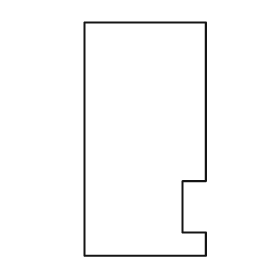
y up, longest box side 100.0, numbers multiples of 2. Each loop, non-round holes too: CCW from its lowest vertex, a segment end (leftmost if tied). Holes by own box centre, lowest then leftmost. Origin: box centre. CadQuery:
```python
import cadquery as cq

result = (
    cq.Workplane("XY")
    .moveTo(-26.0, -50.0)
    .lineTo(26.0, -50.0)
    .lineTo(26.0, -40.0)
    .lineTo(16.0, -40.0)
    .lineTo(16.0, -18.0)
    .lineTo(26.0, -18.0)
    .lineTo(26.0, 50.0)
    .lineTo(-26.0, 50.0)
    .close()
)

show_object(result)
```